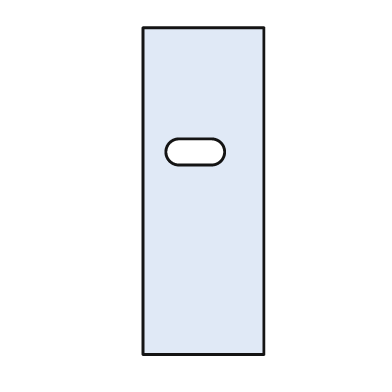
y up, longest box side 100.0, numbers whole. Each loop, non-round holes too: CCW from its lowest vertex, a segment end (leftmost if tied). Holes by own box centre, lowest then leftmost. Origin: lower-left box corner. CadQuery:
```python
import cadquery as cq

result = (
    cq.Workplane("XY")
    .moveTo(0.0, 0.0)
    .lineTo(37.0, 0.0)
    .lineTo(37.0, 100.0)
    .lineTo(0.0, 100.0)
    .close()
    .moveTo(11.0, 58.0)
    .lineTo(21.0, 58.0)
    .threePointArc((25.0, 62.0), (21.0, 66.0))
    .lineTo(11.0, 66.0)
    .threePointArc((7.0, 62.0), (11.0, 58.0))
    .close()
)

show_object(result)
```